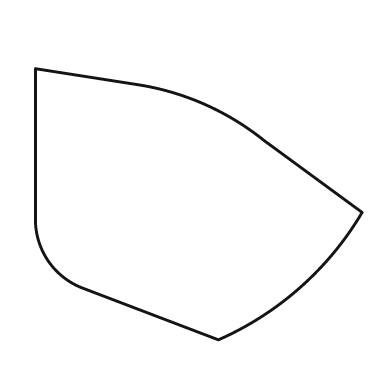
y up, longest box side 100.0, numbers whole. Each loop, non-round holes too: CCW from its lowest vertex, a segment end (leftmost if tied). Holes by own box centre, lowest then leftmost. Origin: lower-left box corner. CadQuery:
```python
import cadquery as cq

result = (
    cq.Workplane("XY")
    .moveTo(56.0, 0.0)
    .threePointArc((81.0, 16.0), (100.0, 39.0))
    .lineTo(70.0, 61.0)
    .threePointArc((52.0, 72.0), (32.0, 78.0))
    .lineTo(0.0, 83.0)
    .lineTo(0.0, 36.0)
    .threePointArc((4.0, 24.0), (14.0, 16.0))
    .close()
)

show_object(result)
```